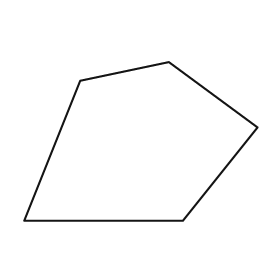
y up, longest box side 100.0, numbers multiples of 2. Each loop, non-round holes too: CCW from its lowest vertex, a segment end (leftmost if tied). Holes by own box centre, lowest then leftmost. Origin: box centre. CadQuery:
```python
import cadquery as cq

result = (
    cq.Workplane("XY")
    .moveTo(-50.0, -34.0)
    .lineTo(18.0, -34.0)
    .lineTo(50.0, 6.0)
    .lineTo(12.0, 34.0)
    .lineTo(-26.0, 26.0)
    .close()
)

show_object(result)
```